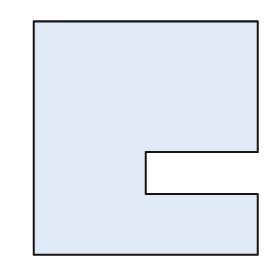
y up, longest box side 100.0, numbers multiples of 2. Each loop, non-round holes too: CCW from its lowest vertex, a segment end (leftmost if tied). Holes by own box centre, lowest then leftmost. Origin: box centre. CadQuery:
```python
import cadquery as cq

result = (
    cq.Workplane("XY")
    .moveTo(-48.0, -50.0)
    .lineTo(48.0, -50.0)
    .lineTo(48.0, -24.0)
    .lineTo(0.0, -24.0)
    .lineTo(0.0, -6.0)
    .lineTo(48.0, -6.0)
    .lineTo(48.0, 50.0)
    .lineTo(-48.0, 50.0)
    .close()
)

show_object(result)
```